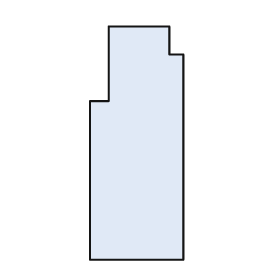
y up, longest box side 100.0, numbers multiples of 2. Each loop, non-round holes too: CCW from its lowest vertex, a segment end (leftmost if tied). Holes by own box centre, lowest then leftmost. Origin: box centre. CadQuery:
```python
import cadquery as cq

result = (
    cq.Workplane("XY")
    .moveTo(-20.0, -50.0)
    .lineTo(20.0, -50.0)
    .lineTo(20.0, 38.0)
    .lineTo(14.0, 38.0)
    .lineTo(14.0, 50.0)
    .lineTo(-12.0, 50.0)
    .lineTo(-12.0, 18.0)
    .lineTo(-20.0, 18.0)
    .close()
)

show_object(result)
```